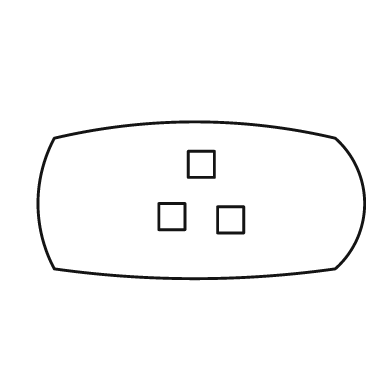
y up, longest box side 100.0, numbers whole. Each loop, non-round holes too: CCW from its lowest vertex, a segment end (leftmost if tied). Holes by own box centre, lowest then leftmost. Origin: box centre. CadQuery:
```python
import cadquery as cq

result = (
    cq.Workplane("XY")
    .moveTo(-45.0, -21.0)
    .threePointArc((-2.0, -24.0), (41.0, -21.0))
    .threePointArc((50.0, -1.0), (41.0, 19.0))
    .threePointArc((-2.0, 24.0), (-45.0, 19.0))
    .threePointArc((-50.0, -1.0), (-45.0, -21.0))
    .close()
    .moveTo(5.0, -10.0)
    .lineTo(13.0, -10.0)
    .lineTo(13.0, -2.0)
    .lineTo(5.0, -2.0)
    .close()
    .moveTo(-13.0, -9.0)
    .lineTo(-5.0, -9.0)
    .lineTo(-5.0, -1.0)
    .lineTo(-13.0, -1.0)
    .close()
    .moveTo(-4.0, 7.0)
    .lineTo(4.0, 7.0)
    .lineTo(4.0, 15.0)
    .lineTo(-4.0, 15.0)
    .close()
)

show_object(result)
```